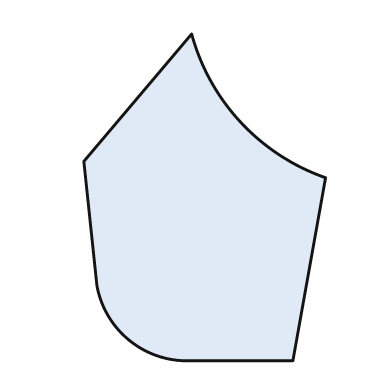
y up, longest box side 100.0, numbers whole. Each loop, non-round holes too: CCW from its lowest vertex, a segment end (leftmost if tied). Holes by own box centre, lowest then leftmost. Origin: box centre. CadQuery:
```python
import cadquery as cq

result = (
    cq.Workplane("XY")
    .moveTo(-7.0, -50.0)
    .lineTo(27.0, -50.0)
    .lineTo(37.0, 6.0)
    .threePointArc((11.0, 23.0), (-4.0, 50.0))
    .lineTo(-37.0, 11.0)
    .lineTo(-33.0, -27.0)
    .threePointArc((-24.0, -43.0), (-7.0, -50.0))
    .close()
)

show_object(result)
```